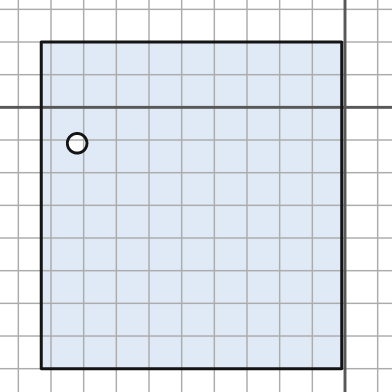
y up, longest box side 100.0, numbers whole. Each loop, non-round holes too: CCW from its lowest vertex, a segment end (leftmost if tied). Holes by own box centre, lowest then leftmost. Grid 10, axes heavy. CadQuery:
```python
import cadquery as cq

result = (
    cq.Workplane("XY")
    .moveTo(-93.0, -80.0)
    .lineTo(-1.0, -80.0)
    .lineTo(-1.0, 20.0)
    .lineTo(-93.0, 20.0)
    .close()
    .moveTo(-82.0, -11.0)
    .circle(3.0)
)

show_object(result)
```